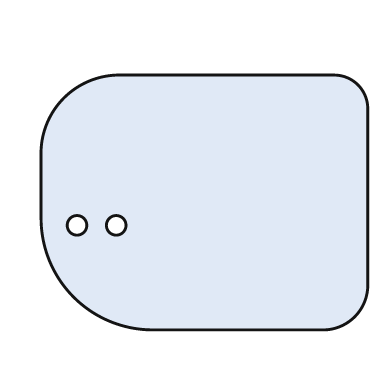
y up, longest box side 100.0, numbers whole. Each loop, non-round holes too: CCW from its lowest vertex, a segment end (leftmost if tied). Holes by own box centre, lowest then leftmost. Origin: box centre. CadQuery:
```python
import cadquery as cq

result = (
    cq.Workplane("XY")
    .moveTo(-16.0, -39.0)
    .lineTo(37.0, -39.0)
    .threePointArc((46.0, -35.0), (50.0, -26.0))
    .lineTo(50.0, 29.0)
    .threePointArc((47.0, 36.0), (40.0, 39.0))
    .lineTo(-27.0, 39.0)
    .threePointArc((-43.0, 32.0), (-50.0, 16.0))
    .lineTo(-50.0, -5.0)
    .threePointArc((-40.0, -29.0), (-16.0, -39.0))
    .close()
    .moveTo(-39.0, -7.0)
    .circle(3.0)
    .moveTo(-27.0, -7.0)
    .circle(3.0)
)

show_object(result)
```